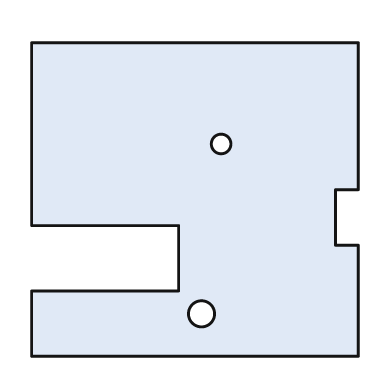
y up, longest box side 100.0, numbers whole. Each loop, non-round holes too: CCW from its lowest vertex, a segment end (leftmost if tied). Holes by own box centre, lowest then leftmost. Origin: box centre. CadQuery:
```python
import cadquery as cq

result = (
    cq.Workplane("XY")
    .moveTo(-50.0, -48.0)
    .lineTo(50.0, -48.0)
    .lineTo(50.0, -14.0)
    .lineTo(43.0, -14.0)
    .lineTo(43.0, 3.0)
    .lineTo(50.0, 3.0)
    .lineTo(50.0, 48.0)
    .lineTo(-50.0, 48.0)
    .lineTo(-50.0, -8.0)
    .lineTo(-5.0, -8.0)
    .lineTo(-5.0, -28.0)
    .lineTo(-50.0, -28.0)
    .close()
    .moveTo(2.0, -35.0)
    .circle(4.0)
    .moveTo(8.0, 17.0)
    .circle(3.0)
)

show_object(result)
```